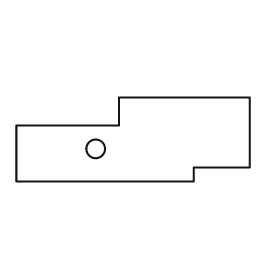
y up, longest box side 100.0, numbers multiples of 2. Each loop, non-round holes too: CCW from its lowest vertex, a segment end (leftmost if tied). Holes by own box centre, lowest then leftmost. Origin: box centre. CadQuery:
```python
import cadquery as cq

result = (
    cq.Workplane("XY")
    .moveTo(-50.0, -18.0)
    .lineTo(26.0, -18.0)
    .lineTo(26.0, -12.0)
    .lineTo(50.0, -12.0)
    .lineTo(50.0, 18.0)
    .lineTo(-6.0, 18.0)
    .lineTo(-6.0, 6.0)
    .lineTo(-50.0, 6.0)
    .close()
    .moveTo(-16.0, -4.0)
    .circle(4.0)
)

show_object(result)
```